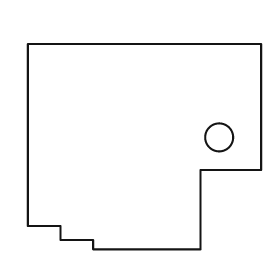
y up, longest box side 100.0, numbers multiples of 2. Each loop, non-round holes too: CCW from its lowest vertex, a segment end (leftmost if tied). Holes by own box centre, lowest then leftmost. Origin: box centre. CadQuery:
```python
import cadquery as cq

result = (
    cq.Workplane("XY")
    .moveTo(-22.0, -44.0)
    .lineTo(24.0, -44.0)
    .lineTo(24.0, -10.0)
    .lineTo(50.0, -10.0)
    .lineTo(50.0, 44.0)
    .lineTo(-50.0, 44.0)
    .lineTo(-50.0, -34.0)
    .lineTo(-36.0, -34.0)
    .lineTo(-36.0, -40.0)
    .lineTo(-22.0, -40.0)
    .close()
    .moveTo(32.0, 4.0)
    .circle(6.0)
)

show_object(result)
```